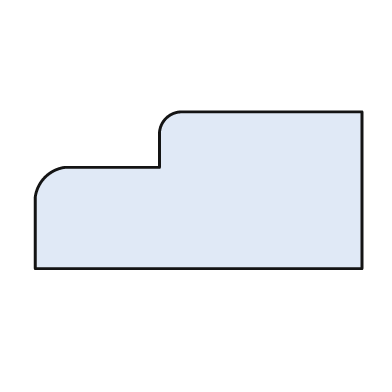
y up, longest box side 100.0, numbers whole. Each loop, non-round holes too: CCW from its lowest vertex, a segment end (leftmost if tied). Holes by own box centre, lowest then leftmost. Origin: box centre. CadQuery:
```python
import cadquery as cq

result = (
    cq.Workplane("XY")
    .moveTo(-50.0, -24.0)
    .lineTo(50.0, -24.0)
    .lineTo(50.0, 24.0)
    .lineTo(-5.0, 24.0)
    .threePointArc((-10.0, 22.0), (-12.0, 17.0))
    .lineTo(-12.0, 7.0)
    .lineTo(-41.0, 7.0)
    .threePointArc((-47.0, 4.0), (-50.0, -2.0))
    .close()
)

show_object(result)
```